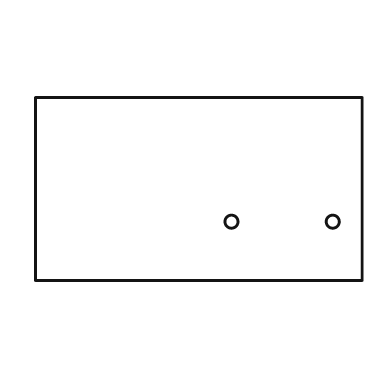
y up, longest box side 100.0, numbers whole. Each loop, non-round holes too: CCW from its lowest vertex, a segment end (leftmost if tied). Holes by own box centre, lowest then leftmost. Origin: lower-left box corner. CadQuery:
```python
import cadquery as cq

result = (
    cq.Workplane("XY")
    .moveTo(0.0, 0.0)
    .lineTo(100.0, 0.0)
    .lineTo(100.0, 56.0)
    .lineTo(0.0, 56.0)
    .close()
    .moveTo(60.0, 18.0)
    .circle(2.0)
    .moveTo(91.0, 18.0)
    .circle(2.0)
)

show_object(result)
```